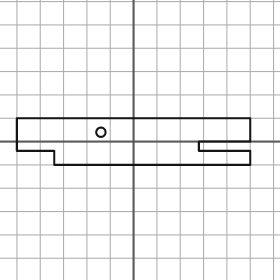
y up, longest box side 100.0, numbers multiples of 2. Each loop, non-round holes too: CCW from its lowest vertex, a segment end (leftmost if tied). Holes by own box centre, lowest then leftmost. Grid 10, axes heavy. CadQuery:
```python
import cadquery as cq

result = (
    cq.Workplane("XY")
    .moveTo(-34.0, -10.0)
    .lineTo(50.0, -10.0)
    .lineTo(50.0, -4.0)
    .lineTo(28.0, -4.0)
    .lineTo(28.0, 0.0)
    .lineTo(50.0, 0.0)
    .lineTo(50.0, 10.0)
    .lineTo(-50.0, 10.0)
    .lineTo(-50.0, -4.0)
    .lineTo(-34.0, -4.0)
    .close()
    .moveTo(-14.0, 4.0)
    .circle(2.0)
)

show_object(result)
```